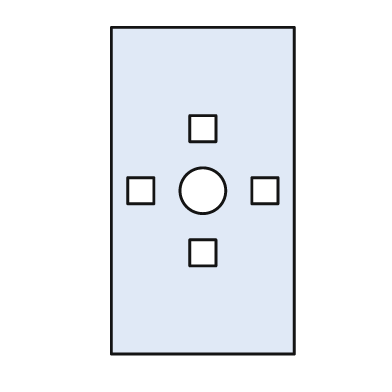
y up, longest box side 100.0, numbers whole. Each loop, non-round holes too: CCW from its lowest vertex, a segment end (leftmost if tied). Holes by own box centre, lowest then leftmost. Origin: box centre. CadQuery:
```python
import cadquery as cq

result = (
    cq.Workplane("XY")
    .moveTo(-28.0, -50.0)
    .lineTo(28.0, -50.0)
    .lineTo(28.0, 50.0)
    .lineTo(-28.0, 50.0)
    .close()
    .moveTo(-4.0, -23.0)
    .lineTo(4.0, -23.0)
    .lineTo(4.0, -15.0)
    .lineTo(-4.0, -15.0)
    .close()
    .moveTo(-23.0, -4.0)
    .lineTo(-15.0, -4.0)
    .lineTo(-15.0, 4.0)
    .lineTo(-23.0, 4.0)
    .close()
    .moveTo(0.0, 0.0)
    .circle(7.0)
    .moveTo(15.0, -4.0)
    .lineTo(23.0, -4.0)
    .lineTo(23.0, 4.0)
    .lineTo(15.0, 4.0)
    .close()
    .moveTo(-4.0, 15.0)
    .lineTo(4.0, 15.0)
    .lineTo(4.0, 23.0)
    .lineTo(-4.0, 23.0)
    .close()
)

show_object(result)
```